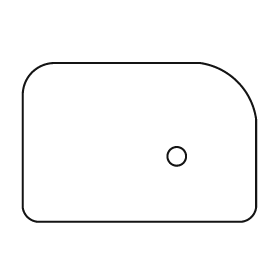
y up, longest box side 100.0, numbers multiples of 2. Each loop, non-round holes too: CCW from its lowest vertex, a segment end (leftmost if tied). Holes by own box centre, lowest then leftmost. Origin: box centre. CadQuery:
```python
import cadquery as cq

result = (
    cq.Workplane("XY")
    .moveTo(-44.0, -34.0)
    .lineTo(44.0, -34.0)
    .threePointArc((48.0, -32.0), (50.0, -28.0))
    .lineTo(50.0, 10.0)
    .threePointArc((42.0, 26.0), (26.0, 34.0))
    .lineTo(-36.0, 34.0)
    .threePointArc((-46.0, 30.0), (-50.0, 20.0))
    .lineTo(-50.0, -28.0)
    .threePointArc((-48.0, -32.0), (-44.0, -34.0))
    .close()
    .moveTo(16.0, -6.0)
    .circle(4.0)
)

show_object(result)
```